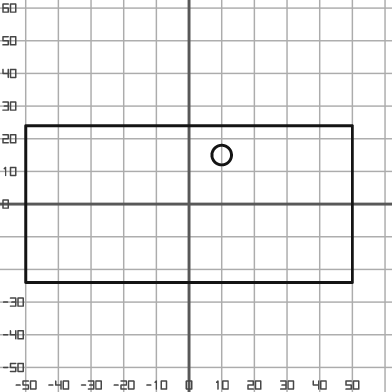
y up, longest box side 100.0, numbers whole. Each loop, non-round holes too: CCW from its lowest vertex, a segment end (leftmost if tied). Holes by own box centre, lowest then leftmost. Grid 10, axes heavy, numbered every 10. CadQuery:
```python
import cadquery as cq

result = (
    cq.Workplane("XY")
    .moveTo(-50.0, -24.0)
    .lineTo(50.0, -24.0)
    .lineTo(50.0, 24.0)
    .lineTo(-50.0, 24.0)
    .close()
    .moveTo(10.0, 15.0)
    .circle(3.0)
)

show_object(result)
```